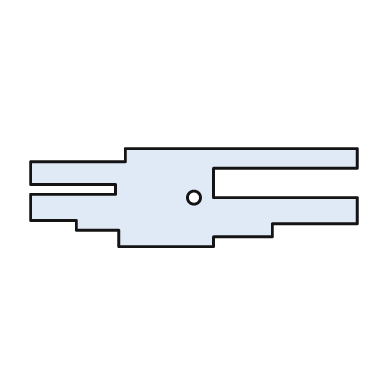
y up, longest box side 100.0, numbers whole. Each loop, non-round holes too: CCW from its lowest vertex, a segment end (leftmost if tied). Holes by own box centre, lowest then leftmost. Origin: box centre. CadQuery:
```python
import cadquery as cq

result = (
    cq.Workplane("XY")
    .moveTo(-23.0, -15.0)
    .lineTo(6.0, -15.0)
    .lineTo(6.0, -12.0)
    .lineTo(24.0, -12.0)
    .lineTo(24.0, -8.0)
    .lineTo(50.0, -8.0)
    .lineTo(50.0, 0.0)
    .lineTo(6.0, 0.0)
    .lineTo(6.0, 9.0)
    .lineTo(50.0, 9.0)
    .lineTo(50.0, 15.0)
    .lineTo(-21.0, 15.0)
    .lineTo(-21.0, 11.0)
    .lineTo(-50.0, 11.0)
    .lineTo(-50.0, 4.0)
    .lineTo(-24.0, 4.0)
    .lineTo(-24.0, 1.0)
    .lineTo(-50.0, 1.0)
    .lineTo(-50.0, -7.0)
    .lineTo(-36.0, -7.0)
    .lineTo(-36.0, -10.0)
    .lineTo(-23.0, -10.0)
    .close()
    .moveTo(0.0, 0.0)
    .circle(2.0)
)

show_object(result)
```